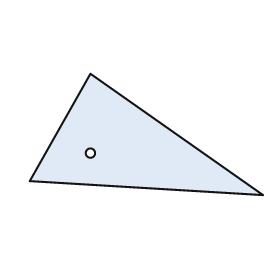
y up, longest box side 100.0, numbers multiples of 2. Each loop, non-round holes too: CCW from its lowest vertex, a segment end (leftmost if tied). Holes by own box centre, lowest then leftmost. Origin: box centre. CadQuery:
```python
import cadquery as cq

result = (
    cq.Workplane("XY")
    .moveTo(50.0, -26.0)
    .lineTo(-24.0, 26.0)
    .lineTo(-50.0, -20.0)
    .close()
    .moveTo(-24.0, -8.0)
    .circle(2.0)
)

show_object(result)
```